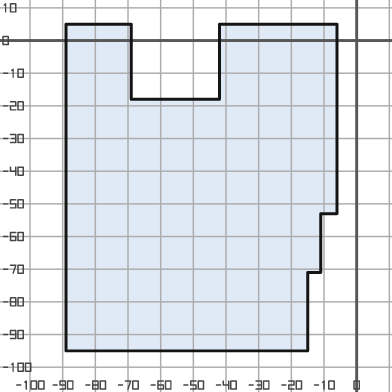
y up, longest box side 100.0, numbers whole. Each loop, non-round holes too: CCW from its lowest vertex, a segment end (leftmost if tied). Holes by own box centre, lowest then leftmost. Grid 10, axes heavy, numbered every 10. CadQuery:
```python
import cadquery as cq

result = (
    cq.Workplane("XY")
    .moveTo(-89.0, -95.0)
    .lineTo(-15.0, -95.0)
    .lineTo(-15.0, -71.0)
    .lineTo(-11.0, -71.0)
    .lineTo(-11.0, -53.0)
    .lineTo(-6.0, -53.0)
    .lineTo(-6.0, 5.0)
    .lineTo(-42.0, 5.0)
    .lineTo(-42.0, -18.0)
    .lineTo(-69.0, -18.0)
    .lineTo(-69.0, 5.0)
    .lineTo(-89.0, 5.0)
    .close()
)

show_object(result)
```